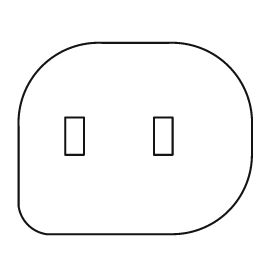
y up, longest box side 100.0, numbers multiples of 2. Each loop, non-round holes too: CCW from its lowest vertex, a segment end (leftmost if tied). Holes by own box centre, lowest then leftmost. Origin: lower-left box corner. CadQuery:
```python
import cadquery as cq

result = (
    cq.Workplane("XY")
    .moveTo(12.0, 0.0)
    .lineTo(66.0, 0.0)
    .threePointArc((90.0, 10.0), (100.0, 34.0))
    .lineTo(100.0, 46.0)
    .threePointArc((90.0, 72.0), (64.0, 82.0))
    .lineTo(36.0, 82.0)
    .threePointArc((10.0, 72.0), (0.0, 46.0))
    .lineTo(0.0, 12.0)
    .threePointArc((4.0, 4.0), (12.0, 0.0))
    .close()
    .moveTo(20.0, 34.0)
    .lineTo(28.0, 34.0)
    .lineTo(28.0, 50.0)
    .lineTo(20.0, 50.0)
    .close()
    .moveTo(58.0, 34.0)
    .lineTo(66.0, 34.0)
    .lineTo(66.0, 50.0)
    .lineTo(58.0, 50.0)
    .close()
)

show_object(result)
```